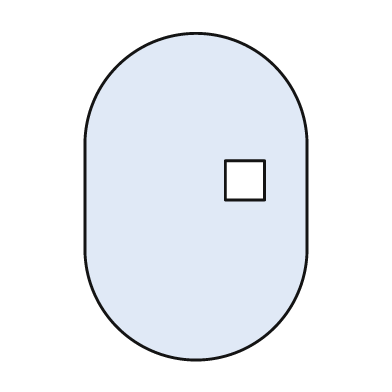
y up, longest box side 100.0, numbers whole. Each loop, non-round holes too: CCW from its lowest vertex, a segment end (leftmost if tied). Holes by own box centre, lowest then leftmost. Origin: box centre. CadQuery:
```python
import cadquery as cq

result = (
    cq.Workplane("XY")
    .moveTo(-34.0, -16.0)
    .threePointArc((0.0, -50.0), (34.0, -16.0))
    .lineTo(34.0, 16.0)
    .threePointArc((0.0, 50.0), (-34.0, 16.0))
    .close()
    .moveTo(9.0, -1.0)
    .lineTo(21.0, -1.0)
    .lineTo(21.0, 11.0)
    .lineTo(9.0, 11.0)
    .close()
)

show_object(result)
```